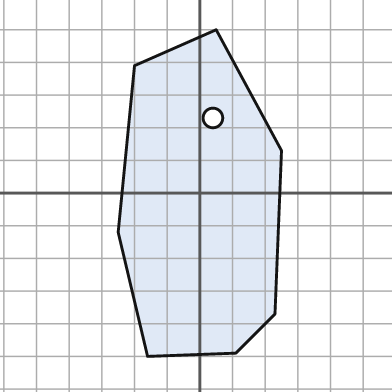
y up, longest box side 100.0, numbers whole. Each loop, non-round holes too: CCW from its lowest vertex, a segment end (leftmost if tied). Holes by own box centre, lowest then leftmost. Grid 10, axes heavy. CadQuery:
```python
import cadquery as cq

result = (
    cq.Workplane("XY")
    .moveTo(-16.0, -50.0)
    .lineTo(11.0, -49.0)
    .lineTo(23.0, -37.0)
    .lineTo(25.0, 13.0)
    .lineTo(5.0, 50.0)
    .lineTo(-20.0, 39.0)
    .lineTo(-25.0, -12.0)
    .close()
    .moveTo(4.0, 23.0)
    .circle(3.0)
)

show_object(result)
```